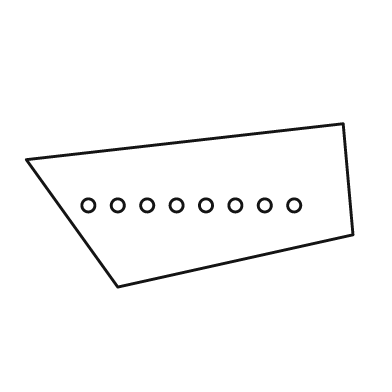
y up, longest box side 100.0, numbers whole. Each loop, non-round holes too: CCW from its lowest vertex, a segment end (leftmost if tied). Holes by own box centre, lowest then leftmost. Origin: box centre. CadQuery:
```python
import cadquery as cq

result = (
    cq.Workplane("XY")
    .moveTo(-22.0, -25.0)
    .lineTo(50.0, -9.0)
    .lineTo(47.0, 25.0)
    .lineTo(-50.0, 14.0)
    .close()
    .moveTo(-31.0, 0.0)
    .circle(2.0)
    .moveTo(-22.0, 0.0)
    .circle(2.0)
    .moveTo(-13.0, 0.0)
    .circle(2.0)
    .moveTo(-4.0, 0.0)
    .circle(2.0)
    .moveTo(5.0, 0.0)
    .circle(2.0)
    .moveTo(14.0, 0.0)
    .circle(2.0)
    .moveTo(23.0, 0.0)
    .circle(2.0)
    .moveTo(32.0, 0.0)
    .circle(2.0)
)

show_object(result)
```